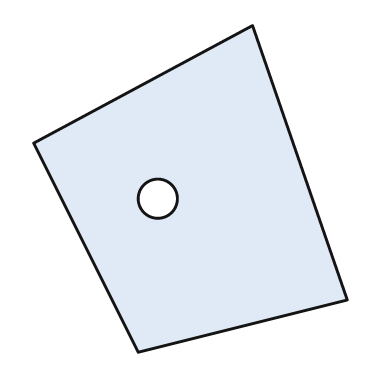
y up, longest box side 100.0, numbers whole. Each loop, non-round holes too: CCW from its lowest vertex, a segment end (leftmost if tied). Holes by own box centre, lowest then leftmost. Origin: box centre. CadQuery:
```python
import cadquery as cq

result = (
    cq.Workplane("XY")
    .moveTo(-16.0, -50.0)
    .lineTo(48.0, -34.0)
    .lineTo(19.0, 50.0)
    .lineTo(-48.0, 14.0)
    .close()
    .moveTo(-10.0, -3.0)
    .circle(6.0)
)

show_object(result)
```